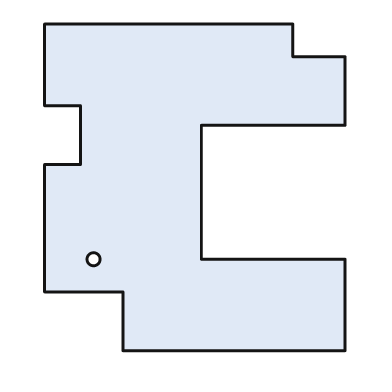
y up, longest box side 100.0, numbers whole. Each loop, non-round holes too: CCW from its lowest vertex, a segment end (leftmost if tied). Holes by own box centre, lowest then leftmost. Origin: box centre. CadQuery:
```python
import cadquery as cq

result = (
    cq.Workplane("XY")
    .moveTo(-22.0, -50.0)
    .lineTo(46.0, -50.0)
    .lineTo(46.0, -22.0)
    .lineTo(2.0, -22.0)
    .lineTo(2.0, 19.0)
    .lineTo(46.0, 19.0)
    .lineTo(46.0, 40.0)
    .lineTo(30.0, 40.0)
    .lineTo(30.0, 50.0)
    .lineTo(-46.0, 50.0)
    .lineTo(-46.0, 25.0)
    .lineTo(-35.0, 25.0)
    .lineTo(-35.0, 7.0)
    .lineTo(-46.0, 7.0)
    .lineTo(-46.0, -32.0)
    .lineTo(-22.0, -32.0)
    .close()
    .moveTo(-31.0, -22.0)
    .circle(2.0)
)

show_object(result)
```